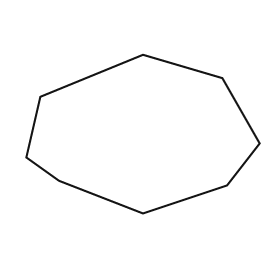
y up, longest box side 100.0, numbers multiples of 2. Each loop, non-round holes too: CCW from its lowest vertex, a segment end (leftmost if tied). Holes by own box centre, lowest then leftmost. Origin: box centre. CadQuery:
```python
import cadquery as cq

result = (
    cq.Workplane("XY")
    .moveTo(0.0, -34.0)
    .lineTo(36.0, -22.0)
    .lineTo(50.0, -4.0)
    .lineTo(34.0, 24.0)
    .lineTo(0.0, 34.0)
    .lineTo(-44.0, 16.0)
    .lineTo(-50.0, -10.0)
    .lineTo(-36.0, -20.0)
    .close()
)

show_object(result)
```